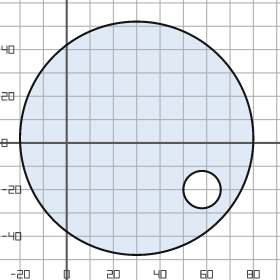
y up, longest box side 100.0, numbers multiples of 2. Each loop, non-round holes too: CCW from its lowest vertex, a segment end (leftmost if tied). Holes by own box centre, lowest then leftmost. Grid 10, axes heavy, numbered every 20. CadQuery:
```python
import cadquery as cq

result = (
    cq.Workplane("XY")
    .moveTo(30.0, 2.0)
    .circle(50.0)
    .moveTo(58.0, -20.0)
    .circle(8.0)
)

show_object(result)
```